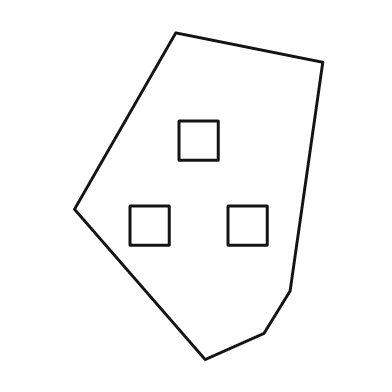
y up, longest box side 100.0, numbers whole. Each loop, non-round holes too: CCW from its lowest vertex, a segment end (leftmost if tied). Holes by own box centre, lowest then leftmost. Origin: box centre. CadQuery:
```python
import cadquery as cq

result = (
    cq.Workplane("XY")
    .moveTo(2.0, -50.0)
    .lineTo(20.0, -42.0)
    .lineTo(28.0, -29.0)
    .lineTo(38.0, 41.0)
    .lineTo(-7.0, 50.0)
    .lineTo(-38.0, -4.0)
    .close()
    .moveTo(-21.0, -15.0)
    .lineTo(-9.0, -15.0)
    .lineTo(-9.0, -3.0)
    .lineTo(-21.0, -3.0)
    .close()
    .moveTo(9.0, -15.0)
    .lineTo(21.0, -15.0)
    .lineTo(21.0, -3.0)
    .lineTo(9.0, -3.0)
    .close()
    .moveTo(-6.0, 11.0)
    .lineTo(6.0, 11.0)
    .lineTo(6.0, 23.0)
    .lineTo(-6.0, 23.0)
    .close()
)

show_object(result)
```